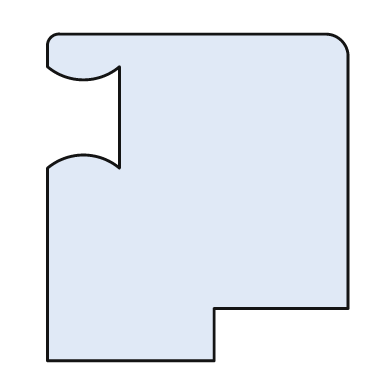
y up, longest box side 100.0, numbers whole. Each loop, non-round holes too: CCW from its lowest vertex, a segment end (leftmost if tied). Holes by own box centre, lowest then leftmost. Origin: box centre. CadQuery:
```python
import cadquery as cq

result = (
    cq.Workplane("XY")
    .moveTo(-46.0, -50.0)
    .lineTo(5.0, -50.0)
    .lineTo(5.0, -34.0)
    .lineTo(46.0, -34.0)
    .lineTo(46.0, 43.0)
    .threePointArc((44.0, 48.0), (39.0, 50.0))
    .lineTo(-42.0, 50.0)
    .threePointArc((-45.0, 49.0), (-46.0, 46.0))
    .lineTo(-46.0, 40.0)
    .threePointArc((-35.0, 36.0), (-24.0, 40.0))
    .lineTo(-24.0, 9.0)
    .threePointArc((-35.0, 13.0), (-46.0, 9.0))
    .close()
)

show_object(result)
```